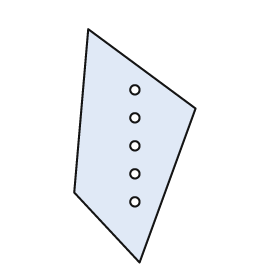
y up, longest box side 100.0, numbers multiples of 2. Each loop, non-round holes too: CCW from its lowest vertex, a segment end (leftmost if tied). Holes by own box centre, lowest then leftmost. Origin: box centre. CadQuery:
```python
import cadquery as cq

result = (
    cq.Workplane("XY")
    .moveTo(2.0, -50.0)
    .lineTo(26.0, 16.0)
    .lineTo(-20.0, 50.0)
    .lineTo(-26.0, -20.0)
    .close()
    .moveTo(0.0, -24.0)
    .circle(2.0)
    .moveTo(0.0, -12.0)
    .circle(2.0)
    .moveTo(0.0, 0.0)
    .circle(2.0)
    .moveTo(0.0, 12.0)
    .circle(2.0)
    .moveTo(0.0, 24.0)
    .circle(2.0)
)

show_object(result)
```